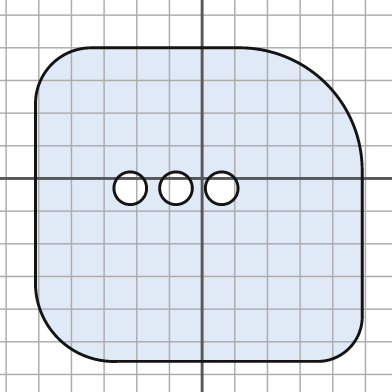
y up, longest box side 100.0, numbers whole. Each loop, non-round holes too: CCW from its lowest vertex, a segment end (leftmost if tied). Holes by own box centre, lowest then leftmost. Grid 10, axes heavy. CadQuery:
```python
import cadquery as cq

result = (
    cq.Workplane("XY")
    .moveTo(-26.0, -56.0)
    .lineTo(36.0, -56.0)
    .threePointArc((45.0, -52.0), (49.0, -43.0))
    .lineTo(49.0, 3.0)
    .threePointArc((38.0, 29.0), (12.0, 40.0))
    .lineTo(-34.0, 40.0)
    .threePointArc((-46.0, 35.0), (-51.0, 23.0))
    .lineTo(-51.0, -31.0)
    .threePointArc((-44.0, -49.0), (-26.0, -56.0))
    .close()
    .moveTo(-22.0, -3.0)
    .circle(5.0)
    .moveTo(-8.0, -3.0)
    .circle(5.0)
    .moveTo(6.0, -3.0)
    .circle(5.0)
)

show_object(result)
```